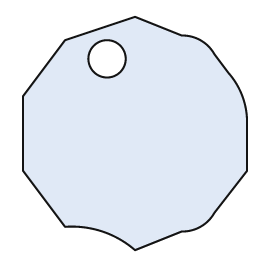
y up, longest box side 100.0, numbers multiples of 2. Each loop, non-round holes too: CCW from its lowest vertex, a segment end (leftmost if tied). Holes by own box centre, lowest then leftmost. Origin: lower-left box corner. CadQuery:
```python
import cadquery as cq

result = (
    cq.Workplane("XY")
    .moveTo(48.0, 0.0)
    .lineTo(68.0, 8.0)
    .threePointArc((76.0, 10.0), (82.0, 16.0))
    .lineTo(96.0, 34.0)
    .lineTo(96.0, 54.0)
    .threePointArc((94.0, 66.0), (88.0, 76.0))
    .lineTo(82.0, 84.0)
    .threePointArc((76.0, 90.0), (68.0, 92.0))
    .lineTo(48.0, 100.0)
    .lineTo(18.0, 90.0)
    .lineTo(0.0, 66.0)
    .lineTo(0.0, 34.0)
    .lineTo(18.0, 10.0)
    .threePointArc((34.0, 8.0), (48.0, 0.0))
    .close()
    .moveTo(36.0, 82.0)
    .circle(8.0)
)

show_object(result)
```